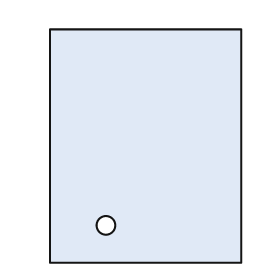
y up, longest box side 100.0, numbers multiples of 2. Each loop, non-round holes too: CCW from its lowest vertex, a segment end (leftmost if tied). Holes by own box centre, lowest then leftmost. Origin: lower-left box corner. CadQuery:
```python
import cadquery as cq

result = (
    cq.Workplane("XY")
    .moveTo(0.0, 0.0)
    .lineTo(82.0, 0.0)
    .lineTo(82.0, 100.0)
    .lineTo(0.0, 100.0)
    .close()
    .moveTo(24.0, 16.0)
    .circle(4.0)
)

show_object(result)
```